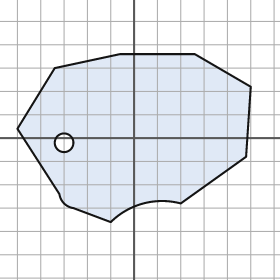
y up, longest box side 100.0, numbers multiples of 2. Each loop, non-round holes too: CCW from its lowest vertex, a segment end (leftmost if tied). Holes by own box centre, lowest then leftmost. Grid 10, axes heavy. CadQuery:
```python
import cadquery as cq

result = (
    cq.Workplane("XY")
    .moveTo(-10.0, -36.0)
    .threePointArc((4.0, -28.0), (20.0, -28.0))
    .lineTo(48.0, -8.0)
    .lineTo(50.0, 22.0)
    .lineTo(26.0, 36.0)
    .lineTo(-6.0, 36.0)
    .lineTo(-34.0, 30.0)
    .lineTo(-50.0, 4.0)
    .lineTo(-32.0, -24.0)
    .threePointArc((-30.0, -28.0), (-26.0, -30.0))
    .close()
    .moveTo(-30.0, -2.0)
    .circle(4.0)
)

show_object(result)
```